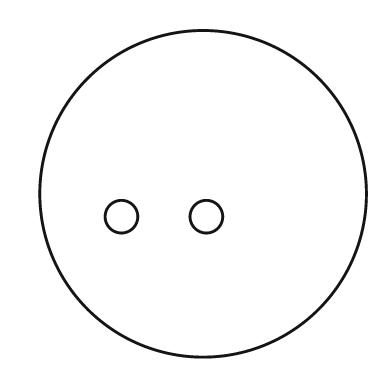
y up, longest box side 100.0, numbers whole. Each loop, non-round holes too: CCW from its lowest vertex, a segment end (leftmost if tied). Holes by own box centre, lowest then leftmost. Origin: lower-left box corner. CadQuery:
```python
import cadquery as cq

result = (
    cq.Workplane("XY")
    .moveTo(50.0, 50.0)
    .circle(50.0)
    .moveTo(25.0, 43.0)
    .circle(5.0)
    .moveTo(51.0, 43.0)
    .circle(5.0)
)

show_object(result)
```